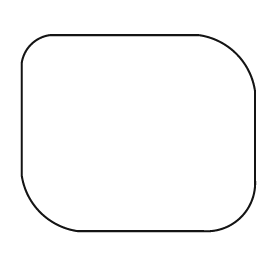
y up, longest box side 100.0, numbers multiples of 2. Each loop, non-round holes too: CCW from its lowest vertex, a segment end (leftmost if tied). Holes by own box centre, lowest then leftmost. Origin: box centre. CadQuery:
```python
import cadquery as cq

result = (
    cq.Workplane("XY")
    .moveTo(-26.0, -42.0)
    .lineTo(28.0, -42.0)
    .threePointArc((44.0, -36.0), (50.0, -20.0))
    .lineTo(50.0, 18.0)
    .threePointArc((42.0, 34.0), (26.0, 42.0))
    .lineTo(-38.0, 42.0)
    .threePointArc((-46.0, 38.0), (-50.0, 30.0))
    .lineTo(-50.0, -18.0)
    .threePointArc((-42.0, -34.0), (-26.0, -42.0))
    .close()
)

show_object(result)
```